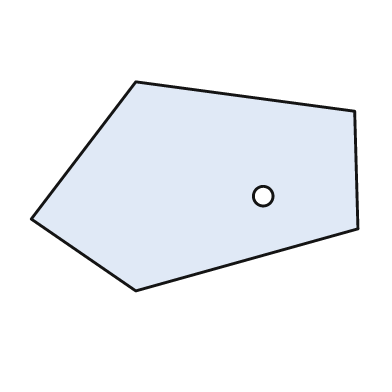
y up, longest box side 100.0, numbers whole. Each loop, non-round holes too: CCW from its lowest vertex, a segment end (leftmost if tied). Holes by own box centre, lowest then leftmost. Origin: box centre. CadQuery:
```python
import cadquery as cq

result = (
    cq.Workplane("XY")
    .moveTo(-18.0, -32.0)
    .lineTo(50.0, -13.0)
    .lineTo(49.0, 23.0)
    .lineTo(-18.0, 32.0)
    .lineTo(-50.0, -10.0)
    .close()
    .moveTo(21.0, -3.0)
    .circle(3.0)
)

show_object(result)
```